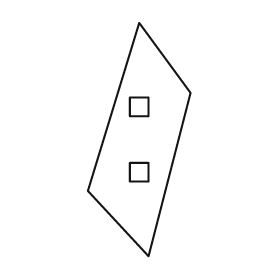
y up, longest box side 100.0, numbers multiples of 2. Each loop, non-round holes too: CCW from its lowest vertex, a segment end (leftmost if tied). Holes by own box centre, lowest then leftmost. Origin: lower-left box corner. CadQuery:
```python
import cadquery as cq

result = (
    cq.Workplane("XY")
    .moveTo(26.0, 0.0)
    .lineTo(44.0, 70.0)
    .lineTo(22.0, 100.0)
    .lineTo(0.0, 28.0)
    .close()
    .moveTo(18.0, 32.0)
    .lineTo(26.0, 32.0)
    .lineTo(26.0, 40.0)
    .lineTo(18.0, 40.0)
    .close()
    .moveTo(18.0, 60.0)
    .lineTo(26.0, 60.0)
    .lineTo(26.0, 68.0)
    .lineTo(18.0, 68.0)
    .close()
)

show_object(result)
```